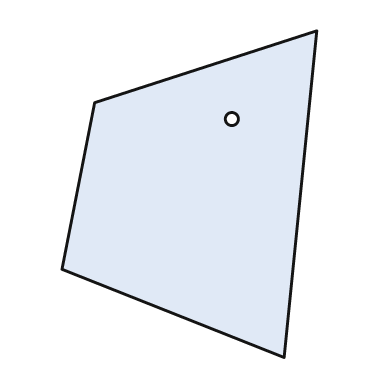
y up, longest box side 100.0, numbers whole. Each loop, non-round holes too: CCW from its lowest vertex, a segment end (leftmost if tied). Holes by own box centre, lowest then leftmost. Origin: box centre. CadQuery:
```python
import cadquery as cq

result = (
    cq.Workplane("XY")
    .moveTo(29.0, -50.0)
    .lineTo(39.0, 50.0)
    .lineTo(-29.0, 28.0)
    .lineTo(-39.0, -23.0)
    .close()
    .moveTo(13.0, 23.0)
    .circle(2.0)
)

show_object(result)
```